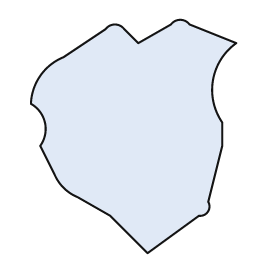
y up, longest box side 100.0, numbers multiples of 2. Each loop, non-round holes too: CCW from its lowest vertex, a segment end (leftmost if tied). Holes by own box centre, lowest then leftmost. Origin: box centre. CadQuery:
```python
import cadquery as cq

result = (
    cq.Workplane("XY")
    .moveTo(6.0, -50.0)
    .lineTo(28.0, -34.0)
    .threePointArc((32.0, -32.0), (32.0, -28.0))
    .lineTo(38.0, -4.0)
    .lineTo(38.0, 6.0)
    .threePointArc((34.0, 24.0), (44.0, 40.0))
    .lineTo(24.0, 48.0)
    .threePointArc((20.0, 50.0), (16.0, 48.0))
    .lineTo(2.0, 40.0)
    .lineTo(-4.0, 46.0)
    .threePointArc((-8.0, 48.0), (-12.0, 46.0))
    .lineTo(-30.0, 34.0)
    .threePointArc((-40.0, 26.0), (-44.0, 14.0))
    .threePointArc((-38.0, 6.0), (-40.0, -4.0))
    .lineTo(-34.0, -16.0)
    .threePointArc((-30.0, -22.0), (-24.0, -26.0))
    .lineTo(-10.0, -34.0)
    .close()
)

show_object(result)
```